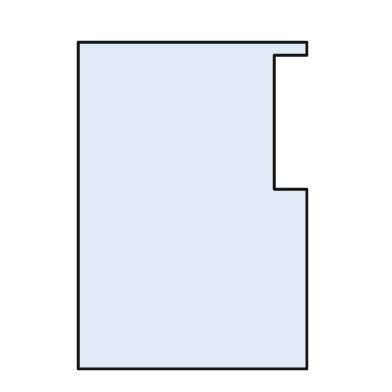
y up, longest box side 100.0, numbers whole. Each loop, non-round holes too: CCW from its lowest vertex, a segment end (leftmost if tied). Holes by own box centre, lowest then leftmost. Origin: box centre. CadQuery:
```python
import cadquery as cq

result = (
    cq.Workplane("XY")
    .moveTo(-35.0, -50.0)
    .lineTo(35.0, -50.0)
    .lineTo(35.0, 5.0)
    .lineTo(25.0, 5.0)
    .lineTo(25.0, 46.0)
    .lineTo(35.0, 46.0)
    .lineTo(35.0, 50.0)
    .lineTo(-35.0, 50.0)
    .close()
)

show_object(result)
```